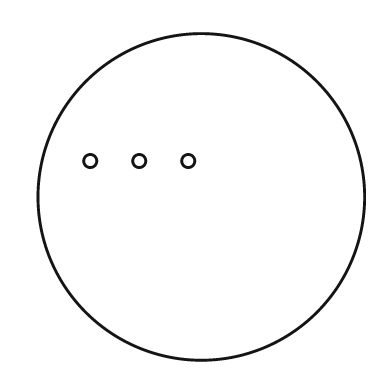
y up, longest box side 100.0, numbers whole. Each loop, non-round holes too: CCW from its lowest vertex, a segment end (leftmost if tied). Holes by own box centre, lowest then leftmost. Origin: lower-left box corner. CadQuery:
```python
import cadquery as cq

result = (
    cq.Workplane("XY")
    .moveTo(50.0, 50.0)
    .circle(50.0)
    .moveTo(16.0, 61.0)
    .circle(2.0)
    .moveTo(31.0, 61.0)
    .circle(2.0)
    .moveTo(46.0, 61.0)
    .circle(2.0)
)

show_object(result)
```